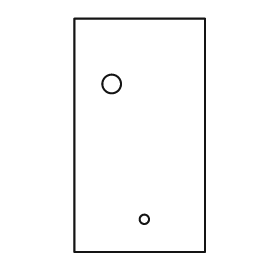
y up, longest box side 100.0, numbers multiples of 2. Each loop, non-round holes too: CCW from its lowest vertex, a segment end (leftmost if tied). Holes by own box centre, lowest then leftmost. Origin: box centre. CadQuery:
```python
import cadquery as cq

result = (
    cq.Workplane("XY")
    .moveTo(-28.0, -50.0)
    .lineTo(28.0, -50.0)
    .lineTo(28.0, 50.0)
    .lineTo(-28.0, 50.0)
    .close()
    .moveTo(2.0, -36.0)
    .circle(2.0)
    .moveTo(-12.0, 22.0)
    .circle(4.0)
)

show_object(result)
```